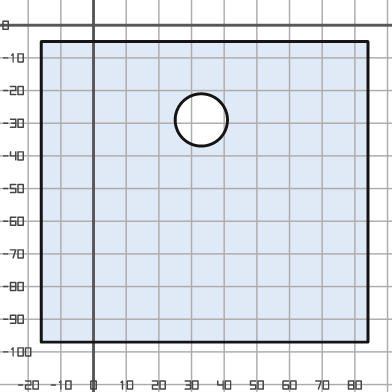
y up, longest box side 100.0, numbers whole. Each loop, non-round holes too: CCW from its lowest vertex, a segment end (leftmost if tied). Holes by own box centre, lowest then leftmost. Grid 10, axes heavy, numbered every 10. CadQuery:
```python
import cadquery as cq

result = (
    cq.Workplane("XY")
    .moveTo(-16.0, -97.0)
    .lineTo(84.0, -97.0)
    .lineTo(84.0, -5.0)
    .lineTo(-16.0, -5.0)
    .close()
    .moveTo(33.0, -29.0)
    .circle(8.0)
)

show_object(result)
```